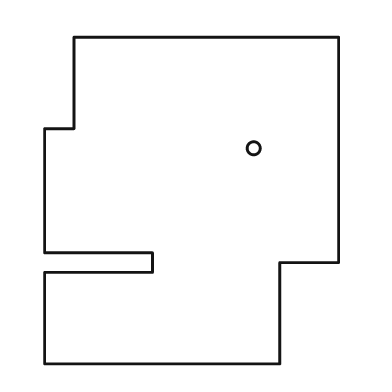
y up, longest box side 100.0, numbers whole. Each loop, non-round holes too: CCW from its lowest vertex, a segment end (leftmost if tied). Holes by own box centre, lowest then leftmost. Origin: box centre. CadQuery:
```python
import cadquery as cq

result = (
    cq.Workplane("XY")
    .moveTo(-45.0, -50.0)
    .lineTo(27.0, -50.0)
    .lineTo(27.0, -19.0)
    .lineTo(45.0, -19.0)
    .lineTo(45.0, 50.0)
    .lineTo(-36.0, 50.0)
    .lineTo(-36.0, 22.0)
    .lineTo(-45.0, 22.0)
    .lineTo(-45.0, -16.0)
    .lineTo(-12.0, -16.0)
    .lineTo(-12.0, -22.0)
    .lineTo(-45.0, -22.0)
    .close()
    .moveTo(19.0, 16.0)
    .circle(2.0)
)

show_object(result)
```